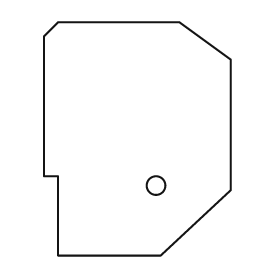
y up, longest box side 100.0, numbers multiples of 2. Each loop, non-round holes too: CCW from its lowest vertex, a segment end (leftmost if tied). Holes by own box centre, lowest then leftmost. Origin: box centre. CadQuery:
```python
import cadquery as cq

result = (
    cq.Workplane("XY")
    .moveTo(-34.0, -50.0)
    .lineTo(10.0, -50.0)
    .lineTo(40.0, -22.0)
    .lineTo(40.0, 34.0)
    .lineTo(18.0, 50.0)
    .lineTo(-34.0, 50.0)
    .lineTo(-40.0, 44.0)
    .lineTo(-40.0, -16.0)
    .lineTo(-34.0, -16.0)
    .close()
    .moveTo(8.0, -20.0)
    .circle(4.0)
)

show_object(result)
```